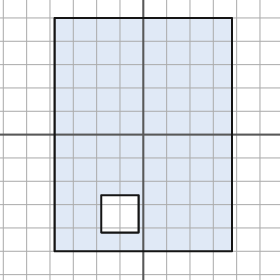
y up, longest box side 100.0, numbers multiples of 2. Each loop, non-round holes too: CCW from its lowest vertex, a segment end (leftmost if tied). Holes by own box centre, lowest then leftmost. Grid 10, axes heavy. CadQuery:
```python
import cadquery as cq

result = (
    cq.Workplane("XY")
    .moveTo(-38.0, -50.0)
    .lineTo(38.0, -50.0)
    .lineTo(38.0, 50.0)
    .lineTo(-38.0, 50.0)
    .close()
    .moveTo(-18.0, -42.0)
    .lineTo(-2.0, -42.0)
    .lineTo(-2.0, -26.0)
    .lineTo(-18.0, -26.0)
    .close()
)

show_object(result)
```